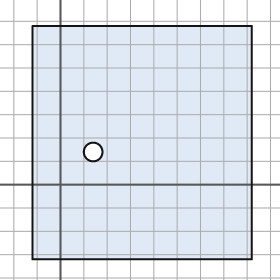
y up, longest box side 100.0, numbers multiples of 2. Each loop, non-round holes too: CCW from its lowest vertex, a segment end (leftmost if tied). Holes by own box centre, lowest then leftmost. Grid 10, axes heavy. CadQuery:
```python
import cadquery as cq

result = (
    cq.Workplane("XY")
    .moveTo(-12.0, -32.0)
    .lineTo(82.0, -32.0)
    .lineTo(82.0, 68.0)
    .lineTo(-12.0, 68.0)
    .close()
    .moveTo(14.0, 14.0)
    .circle(4.0)
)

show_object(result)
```